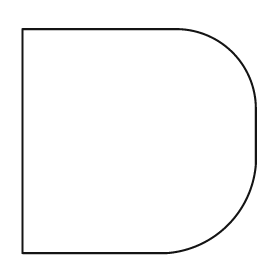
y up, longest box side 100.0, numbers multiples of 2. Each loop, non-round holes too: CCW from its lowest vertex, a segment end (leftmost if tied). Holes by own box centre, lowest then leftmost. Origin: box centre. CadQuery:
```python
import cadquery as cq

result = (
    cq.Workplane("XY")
    .moveTo(-50.0, -48.0)
    .lineTo(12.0, -48.0)
    .threePointArc((38.0, -36.0), (50.0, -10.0))
    .lineTo(50.0, 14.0)
    .threePointArc((40.0, 38.0), (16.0, 48.0))
    .lineTo(-50.0, 48.0)
    .close()
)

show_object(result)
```